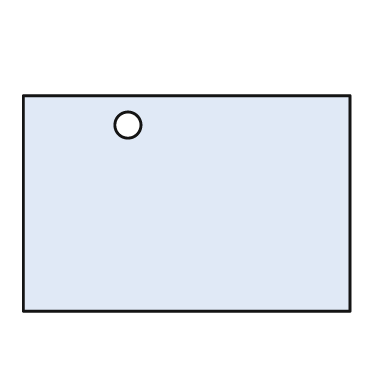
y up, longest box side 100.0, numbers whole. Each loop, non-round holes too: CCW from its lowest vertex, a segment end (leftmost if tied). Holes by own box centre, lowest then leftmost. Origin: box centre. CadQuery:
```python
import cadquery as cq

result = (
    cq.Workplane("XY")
    .moveTo(-50.0, -33.0)
    .lineTo(50.0, -33.0)
    .lineTo(50.0, 33.0)
    .lineTo(-50.0, 33.0)
    .close()
    .moveTo(-18.0, 24.0)
    .circle(4.0)
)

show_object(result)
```